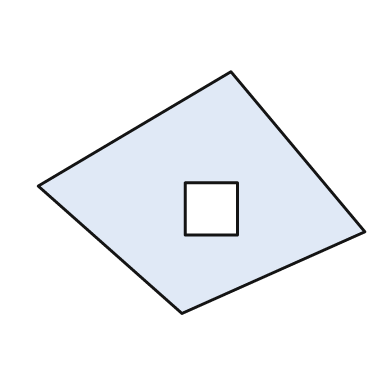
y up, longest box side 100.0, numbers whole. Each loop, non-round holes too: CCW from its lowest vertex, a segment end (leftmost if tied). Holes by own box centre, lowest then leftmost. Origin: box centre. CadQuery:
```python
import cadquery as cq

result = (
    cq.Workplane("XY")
    .moveTo(-6.0, -37.0)
    .lineTo(50.0, -12.0)
    .lineTo(9.0, 37.0)
    .lineTo(-50.0, 2.0)
    .close()
    .moveTo(-5.0, -13.0)
    .lineTo(11.0, -13.0)
    .lineTo(11.0, 3.0)
    .lineTo(-5.0, 3.0)
    .close()
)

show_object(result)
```